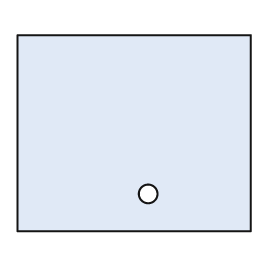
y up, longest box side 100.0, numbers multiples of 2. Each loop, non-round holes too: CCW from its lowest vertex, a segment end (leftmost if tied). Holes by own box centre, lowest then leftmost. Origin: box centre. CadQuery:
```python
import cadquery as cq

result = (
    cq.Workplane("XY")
    .moveTo(-50.0, -42.0)
    .lineTo(50.0, -42.0)
    .lineTo(50.0, 42.0)
    .lineTo(-50.0, 42.0)
    .close()
    .moveTo(6.0, -26.0)
    .circle(4.0)
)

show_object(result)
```